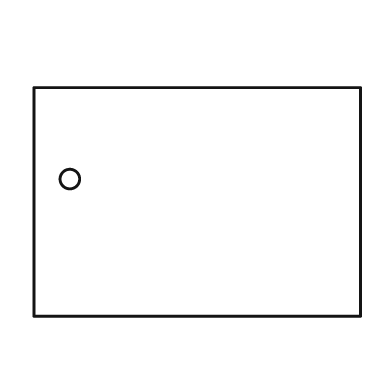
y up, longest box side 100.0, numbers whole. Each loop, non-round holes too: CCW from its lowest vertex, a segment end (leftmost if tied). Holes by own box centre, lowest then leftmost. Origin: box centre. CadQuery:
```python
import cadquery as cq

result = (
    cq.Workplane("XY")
    .moveTo(-50.0, -35.0)
    .lineTo(50.0, -35.0)
    .lineTo(50.0, 35.0)
    .lineTo(-50.0, 35.0)
    .close()
    .moveTo(-39.0, 7.0)
    .circle(3.0)
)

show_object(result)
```